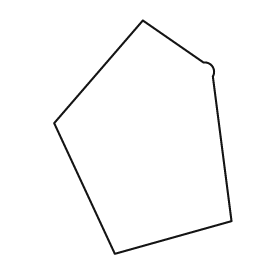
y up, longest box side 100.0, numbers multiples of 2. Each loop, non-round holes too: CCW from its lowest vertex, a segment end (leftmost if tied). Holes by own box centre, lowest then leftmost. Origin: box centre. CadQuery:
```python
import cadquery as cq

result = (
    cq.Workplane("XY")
    .moveTo(-12.0, -50.0)
    .lineTo(38.0, -36.0)
    .lineTo(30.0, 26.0)
    .threePointArc((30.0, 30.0), (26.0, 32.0))
    .lineTo(0.0, 50.0)
    .lineTo(-38.0, 6.0)
    .close()
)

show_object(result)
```